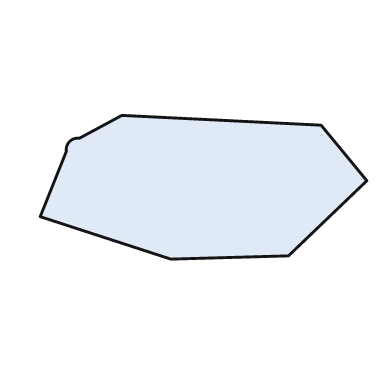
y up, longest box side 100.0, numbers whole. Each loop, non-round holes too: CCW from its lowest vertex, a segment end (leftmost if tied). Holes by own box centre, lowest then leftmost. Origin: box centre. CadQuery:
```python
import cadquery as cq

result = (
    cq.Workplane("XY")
    .moveTo(-10.0, -22.0)
    .lineTo(26.0, -21.0)
    .lineTo(50.0, 2.0)
    .lineTo(36.0, 19.0)
    .lineTo(-25.0, 22.0)
    .lineTo(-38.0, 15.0)
    .threePointArc((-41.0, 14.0), (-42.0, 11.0))
    .lineTo(-50.0, -9.0)
    .close()
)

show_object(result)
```